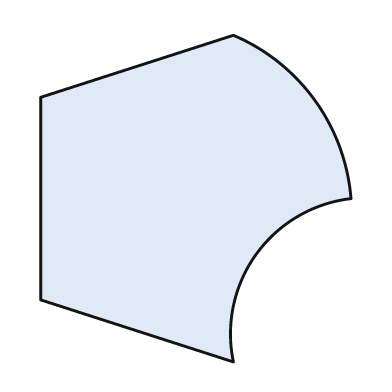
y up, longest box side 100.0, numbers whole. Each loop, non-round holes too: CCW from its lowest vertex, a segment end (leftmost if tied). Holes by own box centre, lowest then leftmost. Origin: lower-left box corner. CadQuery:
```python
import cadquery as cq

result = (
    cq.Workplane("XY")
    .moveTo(59.0, 0.0)
    .threePointArc((66.0, 33.0), (95.0, 50.0))
    .threePointArc((84.0, 80.0), (59.0, 100.0))
    .lineTo(0.0, 81.0)
    .lineTo(0.0, 19.0)
    .close()
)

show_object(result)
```